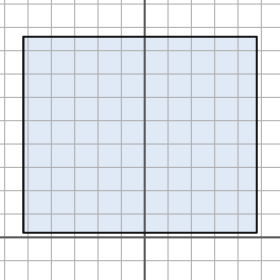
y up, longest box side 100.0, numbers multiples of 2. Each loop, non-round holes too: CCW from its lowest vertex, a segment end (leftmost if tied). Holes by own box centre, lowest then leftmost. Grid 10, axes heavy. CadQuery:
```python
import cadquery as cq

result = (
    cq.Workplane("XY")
    .moveTo(-52.0, 2.0)
    .lineTo(48.0, 2.0)
    .lineTo(48.0, 86.0)
    .lineTo(-52.0, 86.0)
    .close()
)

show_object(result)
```